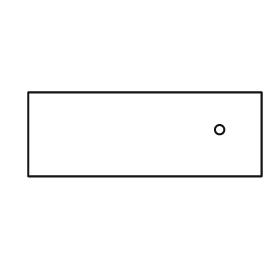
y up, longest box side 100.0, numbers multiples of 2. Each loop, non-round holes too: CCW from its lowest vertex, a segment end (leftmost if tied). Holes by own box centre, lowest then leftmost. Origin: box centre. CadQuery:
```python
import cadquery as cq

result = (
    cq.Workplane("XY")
    .moveTo(-50.0, -18.0)
    .lineTo(50.0, -18.0)
    .lineTo(50.0, 18.0)
    .lineTo(-50.0, 18.0)
    .close()
    .moveTo(32.0, 2.0)
    .circle(2.0)
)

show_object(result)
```